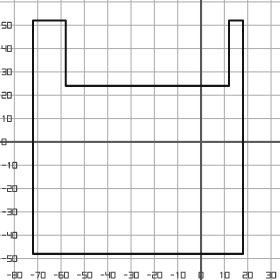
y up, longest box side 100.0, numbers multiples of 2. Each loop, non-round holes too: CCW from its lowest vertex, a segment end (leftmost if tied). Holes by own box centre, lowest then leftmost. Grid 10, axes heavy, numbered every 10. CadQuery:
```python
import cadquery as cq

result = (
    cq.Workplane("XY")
    .moveTo(-72.0, -48.0)
    .lineTo(18.0, -48.0)
    .lineTo(18.0, 52.0)
    .lineTo(12.0, 52.0)
    .lineTo(12.0, 24.0)
    .lineTo(-58.0, 24.0)
    .lineTo(-58.0, 52.0)
    .lineTo(-72.0, 52.0)
    .close()
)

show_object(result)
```